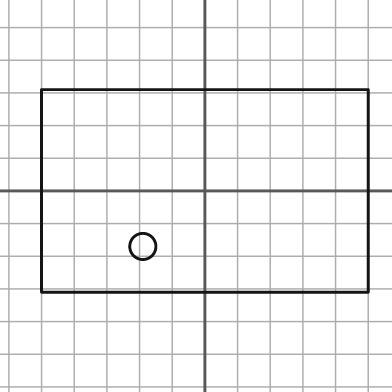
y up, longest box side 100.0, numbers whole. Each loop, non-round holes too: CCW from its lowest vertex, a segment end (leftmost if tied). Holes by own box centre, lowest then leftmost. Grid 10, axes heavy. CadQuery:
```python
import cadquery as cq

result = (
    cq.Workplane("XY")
    .moveTo(-50.0, -31.0)
    .lineTo(50.0, -31.0)
    .lineTo(50.0, 31.0)
    .lineTo(-50.0, 31.0)
    .close()
    .moveTo(-19.0, -17.0)
    .circle(4.0)
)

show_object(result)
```